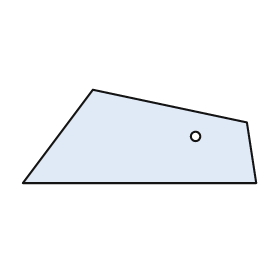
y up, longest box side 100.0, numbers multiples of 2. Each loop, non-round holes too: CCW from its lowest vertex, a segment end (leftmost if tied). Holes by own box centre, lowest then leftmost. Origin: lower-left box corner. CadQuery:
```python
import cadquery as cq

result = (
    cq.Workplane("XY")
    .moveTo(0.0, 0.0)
    .lineTo(100.0, 0.0)
    .lineTo(96.0, 26.0)
    .lineTo(30.0, 40.0)
    .close()
    .moveTo(74.0, 20.0)
    .circle(2.0)
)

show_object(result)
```